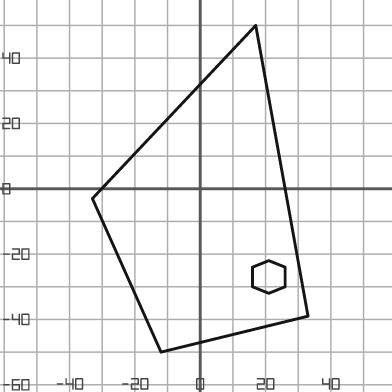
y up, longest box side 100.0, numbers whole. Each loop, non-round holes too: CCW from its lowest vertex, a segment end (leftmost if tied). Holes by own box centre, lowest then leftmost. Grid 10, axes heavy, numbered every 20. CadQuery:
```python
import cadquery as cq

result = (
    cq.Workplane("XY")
    .moveTo(-12.0, -50.0)
    .lineTo(33.0, -39.0)
    .lineTo(17.0, 50.0)
    .lineTo(-33.0, -3.0)
    .close()
    .moveTo(21.0, -32.0)
    .lineTo(26.0, -30.0)
    .lineTo(26.0, -24.0)
    .lineTo(21.0, -22.0)
    .lineTo(16.0, -24.0)
    .lineTo(16.0, -30.0)
    .close()
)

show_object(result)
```